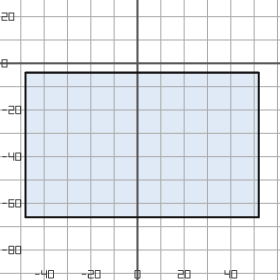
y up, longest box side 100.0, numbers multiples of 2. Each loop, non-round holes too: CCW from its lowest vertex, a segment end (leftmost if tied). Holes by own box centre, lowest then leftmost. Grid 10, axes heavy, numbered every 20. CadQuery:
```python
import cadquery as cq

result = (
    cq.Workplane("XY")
    .moveTo(-48.0, -66.0)
    .lineTo(52.0, -66.0)
    .lineTo(52.0, -4.0)
    .lineTo(-48.0, -4.0)
    .close()
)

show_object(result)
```